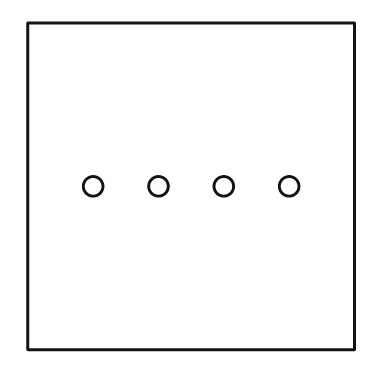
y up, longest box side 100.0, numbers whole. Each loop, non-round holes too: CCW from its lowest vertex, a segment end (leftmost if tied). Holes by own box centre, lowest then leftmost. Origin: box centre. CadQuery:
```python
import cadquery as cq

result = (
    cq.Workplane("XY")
    .moveTo(-50.0, -50.0)
    .lineTo(50.0, -50.0)
    .lineTo(50.0, 50.0)
    .lineTo(-50.0, 50.0)
    .close()
    .moveTo(-30.0, 0.0)
    .circle(3.0)
    .moveTo(-10.0, 0.0)
    .circle(3.0)
    .moveTo(10.0, 0.0)
    .circle(3.0)
    .moveTo(30.0, 0.0)
    .circle(3.0)
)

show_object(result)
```